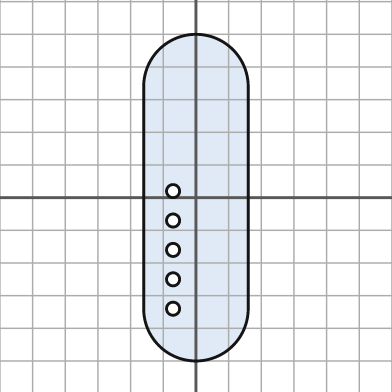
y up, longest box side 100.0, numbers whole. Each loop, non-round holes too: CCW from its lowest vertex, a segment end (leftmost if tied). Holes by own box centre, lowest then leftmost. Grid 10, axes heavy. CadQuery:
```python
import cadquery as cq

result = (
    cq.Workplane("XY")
    .moveTo(-16.0, -34.0)
    .threePointArc((0.0, -50.0), (16.0, -34.0))
    .lineTo(16.0, 34.0)
    .threePointArc((0.0, 50.0), (-16.0, 34.0))
    .close()
    .moveTo(-7.0, -34.0)
    .circle(2.0)
    .moveTo(-7.0, -25.0)
    .circle(2.0)
    .moveTo(-7.0, -16.0)
    .circle(2.0)
    .moveTo(-7.0, -7.0)
    .circle(2.0)
    .moveTo(-7.0, 2.0)
    .circle(2.0)
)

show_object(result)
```